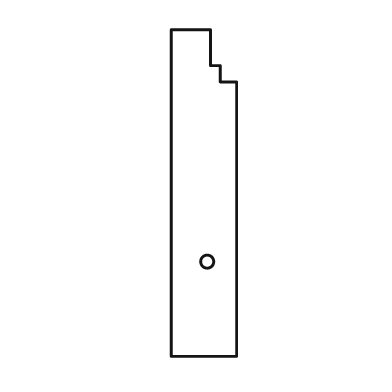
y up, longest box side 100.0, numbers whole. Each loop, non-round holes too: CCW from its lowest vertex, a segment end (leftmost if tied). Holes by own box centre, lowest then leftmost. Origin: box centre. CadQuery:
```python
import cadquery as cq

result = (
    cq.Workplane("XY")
    .moveTo(-10.0, -50.0)
    .lineTo(10.0, -50.0)
    .lineTo(10.0, 34.0)
    .lineTo(5.0, 34.0)
    .lineTo(5.0, 39.0)
    .lineTo(2.0, 39.0)
    .lineTo(2.0, 50.0)
    .lineTo(-10.0, 50.0)
    .close()
    .moveTo(1.0, -21.0)
    .circle(2.0)
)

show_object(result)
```